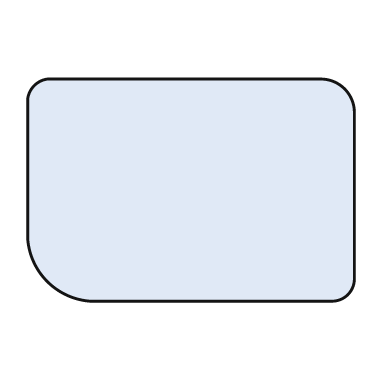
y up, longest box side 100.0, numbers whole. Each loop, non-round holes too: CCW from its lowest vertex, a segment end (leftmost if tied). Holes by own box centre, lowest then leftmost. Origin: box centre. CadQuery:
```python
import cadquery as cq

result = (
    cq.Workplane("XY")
    .moveTo(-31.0, -34.0)
    .lineTo(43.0, -34.0)
    .threePointArc((48.0, -32.0), (50.0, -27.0))
    .lineTo(50.0, 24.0)
    .threePointArc((47.0, 31.0), (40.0, 34.0))
    .lineTo(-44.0, 34.0)
    .threePointArc((-48.0, 32.0), (-50.0, 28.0))
    .lineTo(-50.0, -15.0)
    .threePointArc((-44.0, -28.0), (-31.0, -34.0))
    .close()
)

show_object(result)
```